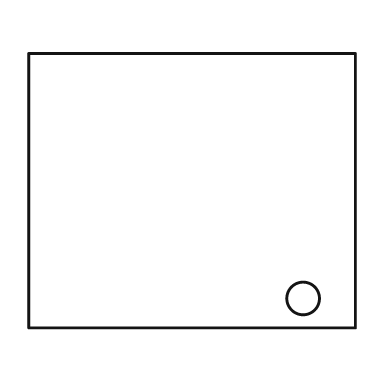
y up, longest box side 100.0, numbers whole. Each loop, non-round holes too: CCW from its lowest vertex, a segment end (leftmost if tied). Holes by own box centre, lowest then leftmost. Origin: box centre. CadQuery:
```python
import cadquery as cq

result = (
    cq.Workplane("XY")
    .moveTo(-50.0, -42.0)
    .lineTo(50.0, -42.0)
    .lineTo(50.0, 42.0)
    .lineTo(-50.0, 42.0)
    .close()
    .moveTo(34.0, -33.0)
    .circle(5.0)
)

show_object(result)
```